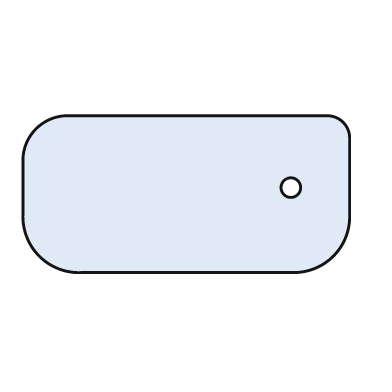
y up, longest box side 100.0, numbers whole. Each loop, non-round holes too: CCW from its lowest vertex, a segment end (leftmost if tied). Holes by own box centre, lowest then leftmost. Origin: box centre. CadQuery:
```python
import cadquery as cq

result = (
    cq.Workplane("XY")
    .moveTo(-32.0, -24.0)
    .lineTo(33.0, -24.0)
    .threePointArc((45.0, -19.0), (50.0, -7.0))
    .lineTo(50.0, 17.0)
    .threePointArc((48.0, 22.0), (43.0, 24.0))
    .lineTo(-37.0, 24.0)
    .threePointArc((-46.0, 20.0), (-50.0, 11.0))
    .lineTo(-50.0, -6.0)
    .threePointArc((-45.0, -19.0), (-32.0, -24.0))
    .close()
    .moveTo(32.0, 2.0)
    .circle(3.0)
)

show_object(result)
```